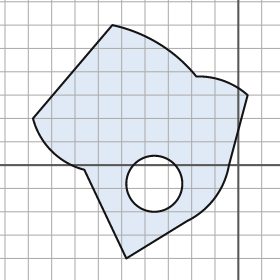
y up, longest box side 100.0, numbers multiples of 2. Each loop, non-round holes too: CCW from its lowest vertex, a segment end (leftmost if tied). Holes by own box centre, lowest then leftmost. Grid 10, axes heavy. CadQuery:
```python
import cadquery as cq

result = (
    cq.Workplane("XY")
    .moveTo(-48.0, -40.0)
    .lineTo(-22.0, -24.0)
    .threePointArc((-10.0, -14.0), (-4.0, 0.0))
    .lineTo(4.0, 30.0)
    .threePointArc((-6.0, 36.0), (-18.0, 38.0))
    .threePointArc((-34.0, 52.0), (-54.0, 60.0))
    .lineTo(-88.0, 20.0)
    .threePointArc((-80.0, 6.0), (-66.0, -2.0))
    .close()
    .moveTo(-36.0, -8.0)
    .circle(12.0)
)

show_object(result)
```